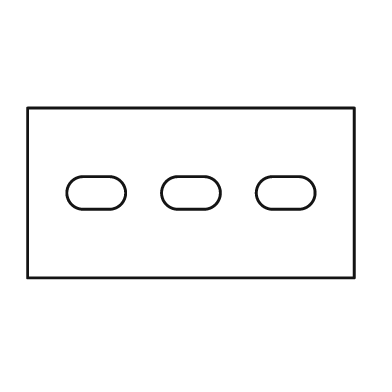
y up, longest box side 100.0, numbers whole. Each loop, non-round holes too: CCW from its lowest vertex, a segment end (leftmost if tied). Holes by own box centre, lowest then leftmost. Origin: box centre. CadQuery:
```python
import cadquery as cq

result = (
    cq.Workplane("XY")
    .moveTo(-50.0, -26.0)
    .lineTo(50.0, -26.0)
    .lineTo(50.0, 26.0)
    .lineTo(-50.0, 26.0)
    .close()
    .moveTo(-33.0, -5.0)
    .lineTo(-25.0, -5.0)
    .threePointArc((-20.0, 0.0), (-25.0, 5.0))
    .lineTo(-33.0, 5.0)
    .threePointArc((-38.0, 0.0), (-33.0, -5.0))
    .close()
    .moveTo(-4.0, -5.0)
    .lineTo(4.0, -5.0)
    .threePointArc((9.0, 0.0), (4.0, 5.0))
    .lineTo(-4.0, 5.0)
    .threePointArc((-9.0, 0.0), (-4.0, -5.0))
    .close()
    .moveTo(25.0, -5.0)
    .lineTo(33.0, -5.0)
    .threePointArc((38.0, 0.0), (33.0, 5.0))
    .lineTo(25.0, 5.0)
    .threePointArc((20.0, 0.0), (25.0, -5.0))
    .close()
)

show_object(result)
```